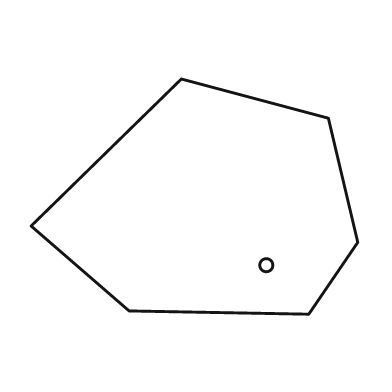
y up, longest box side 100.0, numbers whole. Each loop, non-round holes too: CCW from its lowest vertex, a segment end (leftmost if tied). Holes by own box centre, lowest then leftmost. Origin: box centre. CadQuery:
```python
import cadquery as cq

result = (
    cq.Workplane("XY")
    .moveTo(35.0, -36.0)
    .lineTo(50.0, -14.0)
    .lineTo(41.0, 24.0)
    .lineTo(-4.0, 36.0)
    .lineTo(-50.0, -9.0)
    .lineTo(-20.0, -35.0)
    .close()
    .moveTo(22.0, -21.0)
    .circle(2.0)
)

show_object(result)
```